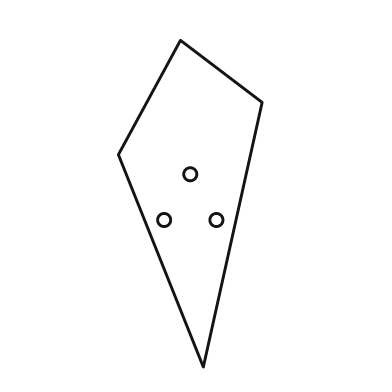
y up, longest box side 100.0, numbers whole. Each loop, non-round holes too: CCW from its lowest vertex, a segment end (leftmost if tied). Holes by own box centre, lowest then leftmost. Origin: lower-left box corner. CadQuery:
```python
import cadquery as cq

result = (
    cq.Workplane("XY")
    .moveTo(26.0, 0.0)
    .lineTo(44.0, 81.0)
    .lineTo(19.0, 100.0)
    .lineTo(0.0, 65.0)
    .close()
    .moveTo(14.0, 45.0)
    .circle(2.0)
    .moveTo(30.0, 45.0)
    .circle(2.0)
    .moveTo(22.0, 59.0)
    .circle(2.0)
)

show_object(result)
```